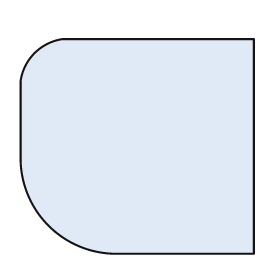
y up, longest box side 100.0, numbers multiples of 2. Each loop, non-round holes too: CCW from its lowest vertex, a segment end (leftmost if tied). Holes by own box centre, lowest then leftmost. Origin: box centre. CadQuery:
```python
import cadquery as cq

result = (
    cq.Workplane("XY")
    .moveTo(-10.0, -46.0)
    .lineTo(50.0, -46.0)
    .lineTo(50.0, 46.0)
    .lineTo(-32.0, 46.0)
    .threePointArc((-44.0, 40.0), (-50.0, 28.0))
    .lineTo(-50.0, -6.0)
    .threePointArc((-38.0, -34.0), (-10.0, -46.0))
    .close()
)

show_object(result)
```